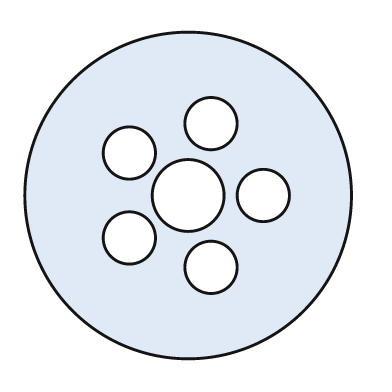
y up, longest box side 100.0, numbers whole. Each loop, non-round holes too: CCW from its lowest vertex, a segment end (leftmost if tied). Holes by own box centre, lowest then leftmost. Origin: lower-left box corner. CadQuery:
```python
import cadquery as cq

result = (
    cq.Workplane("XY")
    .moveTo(50.0, 50.0)
    .circle(50.0)
    .moveTo(57.0, 28.0)
    .circle(8.0)
    .moveTo(32.0, 37.0)
    .circle(8.0)
    .moveTo(50.0, 50.0)
    .circle(11.0)
    .moveTo(73.0, 50.0)
    .circle(8.0)
    .moveTo(32.0, 63.0)
    .circle(8.0)
    .moveTo(57.0, 72.0)
    .circle(8.0)
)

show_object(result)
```